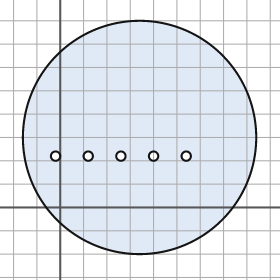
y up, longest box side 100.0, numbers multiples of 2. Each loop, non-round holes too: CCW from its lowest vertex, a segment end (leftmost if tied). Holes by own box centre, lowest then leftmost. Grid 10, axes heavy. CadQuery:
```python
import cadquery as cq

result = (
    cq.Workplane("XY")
    .moveTo(34.0, 30.0)
    .circle(50.0)
    .moveTo(-2.0, 22.0)
    .circle(2.0)
    .moveTo(12.0, 22.0)
    .circle(2.0)
    .moveTo(26.0, 22.0)
    .circle(2.0)
    .moveTo(40.0, 22.0)
    .circle(2.0)
    .moveTo(54.0, 22.0)
    .circle(2.0)
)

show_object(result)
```